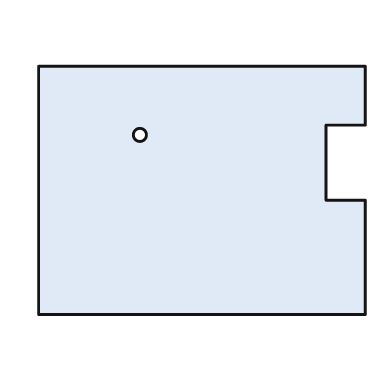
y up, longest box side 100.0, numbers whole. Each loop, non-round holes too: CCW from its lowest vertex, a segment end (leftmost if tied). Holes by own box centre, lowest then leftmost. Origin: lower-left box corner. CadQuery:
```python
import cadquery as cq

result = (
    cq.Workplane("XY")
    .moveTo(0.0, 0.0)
    .lineTo(100.0, 0.0)
    .lineTo(100.0, 35.0)
    .lineTo(88.0, 35.0)
    .lineTo(88.0, 58.0)
    .lineTo(100.0, 58.0)
    .lineTo(100.0, 76.0)
    .lineTo(0.0, 76.0)
    .close()
    .moveTo(31.0, 55.0)
    .circle(2.0)
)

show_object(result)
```